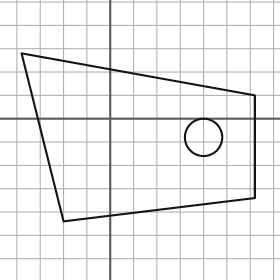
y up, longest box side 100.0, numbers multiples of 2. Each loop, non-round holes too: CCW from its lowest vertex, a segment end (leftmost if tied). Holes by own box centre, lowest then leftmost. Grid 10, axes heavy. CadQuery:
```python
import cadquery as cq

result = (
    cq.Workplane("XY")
    .moveTo(-20.0, -44.0)
    .lineTo(62.0, -34.0)
    .lineTo(62.0, 10.0)
    .lineTo(-38.0, 28.0)
    .close()
    .moveTo(40.0, -8.0)
    .circle(8.0)
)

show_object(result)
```